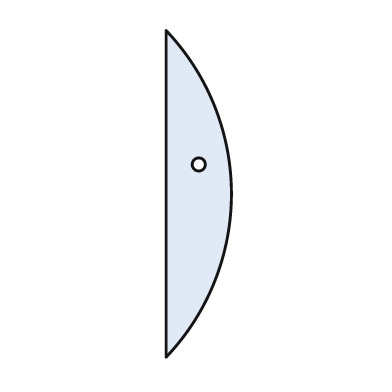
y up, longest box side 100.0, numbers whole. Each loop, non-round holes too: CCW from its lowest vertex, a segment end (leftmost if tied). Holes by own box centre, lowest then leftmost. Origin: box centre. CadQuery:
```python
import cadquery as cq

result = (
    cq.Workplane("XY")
    .moveTo(-10.0, -50.0)
    .threePointArc((10.0, 0.0), (-10.0, 50.0))
    .close()
    .moveTo(0.0, 9.0)
    .circle(2.0)
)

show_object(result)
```